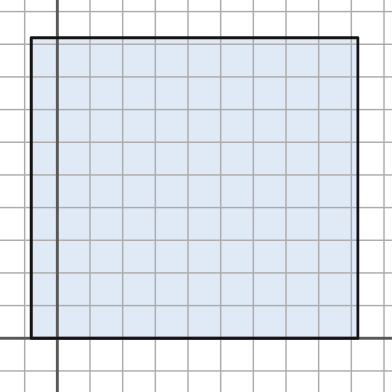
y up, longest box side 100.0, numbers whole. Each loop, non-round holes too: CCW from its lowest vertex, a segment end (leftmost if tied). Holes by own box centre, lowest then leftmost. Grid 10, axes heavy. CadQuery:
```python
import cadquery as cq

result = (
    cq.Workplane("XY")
    .moveTo(-8.0, 0.0)
    .lineTo(92.0, 0.0)
    .lineTo(92.0, 92.0)
    .lineTo(-8.0, 92.0)
    .close()
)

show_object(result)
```